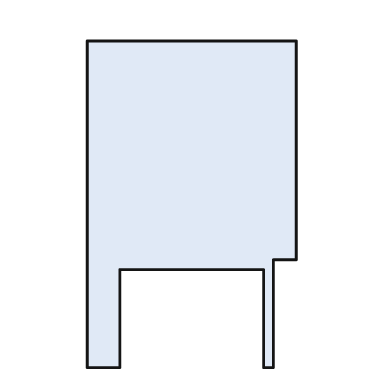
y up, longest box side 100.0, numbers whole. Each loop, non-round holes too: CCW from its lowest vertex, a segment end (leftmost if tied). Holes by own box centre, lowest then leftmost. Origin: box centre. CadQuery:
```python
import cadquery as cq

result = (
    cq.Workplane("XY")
    .moveTo(-32.0, -50.0)
    .lineTo(-22.0, -50.0)
    .lineTo(-22.0, -20.0)
    .lineTo(22.0, -20.0)
    .lineTo(22.0, -50.0)
    .lineTo(25.0, -50.0)
    .lineTo(25.0, -17.0)
    .lineTo(32.0, -17.0)
    .lineTo(32.0, 50.0)
    .lineTo(-32.0, 50.0)
    .close()
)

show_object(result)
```